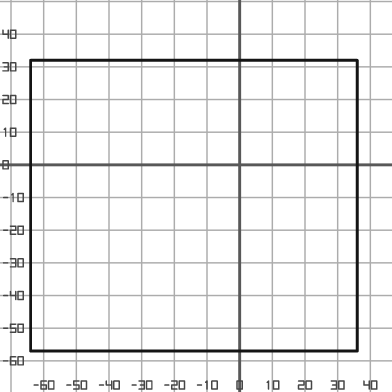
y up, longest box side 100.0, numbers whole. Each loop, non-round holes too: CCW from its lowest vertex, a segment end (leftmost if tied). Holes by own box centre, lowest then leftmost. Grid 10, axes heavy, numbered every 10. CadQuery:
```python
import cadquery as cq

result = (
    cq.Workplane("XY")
    .moveTo(-64.0, -57.0)
    .lineTo(36.0, -57.0)
    .lineTo(36.0, 32.0)
    .lineTo(-64.0, 32.0)
    .close()
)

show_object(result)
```